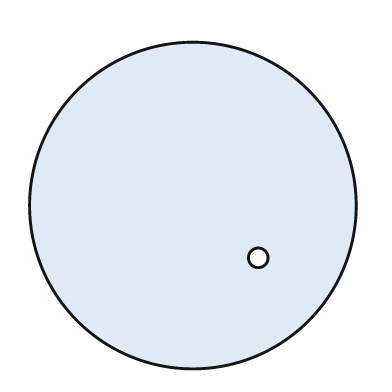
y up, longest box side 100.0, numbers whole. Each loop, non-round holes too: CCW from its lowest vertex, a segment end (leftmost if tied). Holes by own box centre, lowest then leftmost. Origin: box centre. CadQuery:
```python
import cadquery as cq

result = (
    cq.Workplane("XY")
    .moveTo(0.0, 0.0)
    .circle(50.0)
    .moveTo(20.0, -16.0)
    .circle(3.0)
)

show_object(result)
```